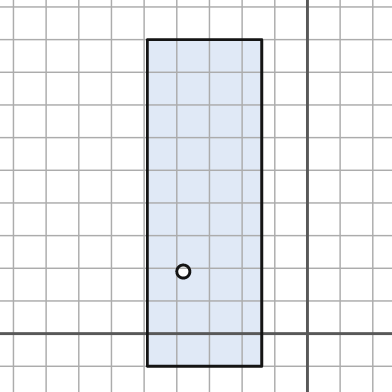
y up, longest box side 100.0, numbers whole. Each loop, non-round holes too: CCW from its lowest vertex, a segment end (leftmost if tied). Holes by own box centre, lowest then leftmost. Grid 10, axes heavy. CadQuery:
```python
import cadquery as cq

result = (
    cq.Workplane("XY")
    .moveTo(-49.0, -10.0)
    .lineTo(-14.0, -10.0)
    .lineTo(-14.0, 90.0)
    .lineTo(-49.0, 90.0)
    .close()
    .moveTo(-38.0, 19.0)
    .circle(2.0)
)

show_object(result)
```